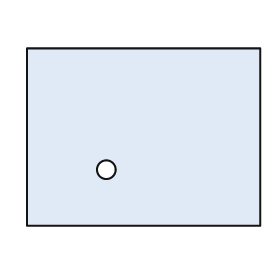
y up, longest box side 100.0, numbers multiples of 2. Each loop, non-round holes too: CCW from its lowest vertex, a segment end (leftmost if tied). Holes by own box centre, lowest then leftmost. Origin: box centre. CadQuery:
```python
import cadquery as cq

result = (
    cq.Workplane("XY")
    .moveTo(-50.0, -38.0)
    .lineTo(50.0, -38.0)
    .lineTo(50.0, 38.0)
    .lineTo(-50.0, 38.0)
    .close()
    .moveTo(-16.0, -14.0)
    .circle(4.0)
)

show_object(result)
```